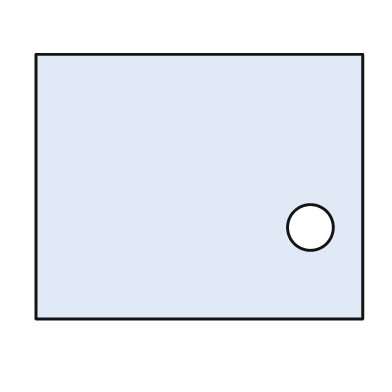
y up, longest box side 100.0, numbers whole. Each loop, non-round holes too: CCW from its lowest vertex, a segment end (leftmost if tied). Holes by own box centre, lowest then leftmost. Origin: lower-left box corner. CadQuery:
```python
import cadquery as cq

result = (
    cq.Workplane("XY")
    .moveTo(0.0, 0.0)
    .lineTo(100.0, 0.0)
    .lineTo(100.0, 81.0)
    .lineTo(0.0, 81.0)
    .close()
    .moveTo(84.0, 28.0)
    .circle(7.0)
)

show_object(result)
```